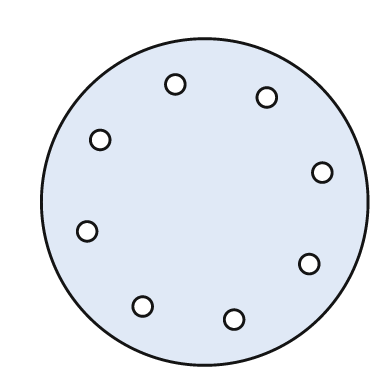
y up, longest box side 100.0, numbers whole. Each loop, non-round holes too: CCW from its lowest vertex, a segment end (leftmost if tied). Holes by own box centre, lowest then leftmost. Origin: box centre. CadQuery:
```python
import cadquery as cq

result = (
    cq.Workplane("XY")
    .moveTo(0.0, 0.0)
    .circle(50.0)
    .moveTo(9.0, -36.0)
    .circle(3.0)
    .moveTo(-19.0, -32.0)
    .circle(3.0)
    .moveTo(32.0, -19.0)
    .circle(3.0)
    .moveTo(-36.0, -9.0)
    .circle(3.0)
    .moveTo(36.0, 9.0)
    .circle(3.0)
    .moveTo(-32.0, 19.0)
    .circle(3.0)
    .moveTo(19.0, 32.0)
    .circle(3.0)
    .moveTo(-9.0, 36.0)
    .circle(3.0)
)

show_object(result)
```